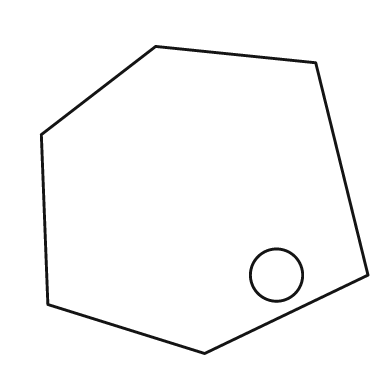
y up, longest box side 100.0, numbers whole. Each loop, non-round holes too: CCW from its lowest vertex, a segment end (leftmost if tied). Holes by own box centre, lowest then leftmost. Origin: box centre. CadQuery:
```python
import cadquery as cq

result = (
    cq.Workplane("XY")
    .moveTo(0.0, -47.0)
    .lineTo(50.0, -23.0)
    .lineTo(34.0, 42.0)
    .lineTo(-15.0, 47.0)
    .lineTo(-50.0, 20.0)
    .lineTo(-48.0, -32.0)
    .close()
    .moveTo(22.0, -23.0)
    .circle(8.0)
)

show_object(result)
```